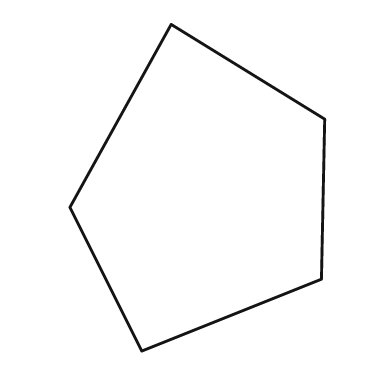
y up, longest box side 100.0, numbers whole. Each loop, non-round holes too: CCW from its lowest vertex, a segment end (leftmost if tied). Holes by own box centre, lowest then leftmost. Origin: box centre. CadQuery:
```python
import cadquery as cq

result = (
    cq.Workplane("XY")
    .moveTo(-17.0, -50.0)
    .lineTo(38.0, -28.0)
    .lineTo(39.0, 21.0)
    .lineTo(-8.0, 50.0)
    .lineTo(-39.0, -6.0)
    .close()
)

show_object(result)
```